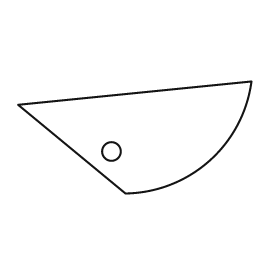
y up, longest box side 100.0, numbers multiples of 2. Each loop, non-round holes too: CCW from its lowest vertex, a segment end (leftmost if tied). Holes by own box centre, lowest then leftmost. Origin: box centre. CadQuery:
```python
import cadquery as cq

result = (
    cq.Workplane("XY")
    .moveTo(-4.0, -24.0)
    .threePointArc((32.0, -10.0), (50.0, 24.0))
    .lineTo(-50.0, 14.0)
    .close()
    .moveTo(-10.0, -6.0)
    .circle(4.0)
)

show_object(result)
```